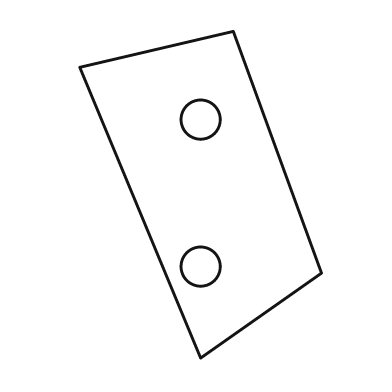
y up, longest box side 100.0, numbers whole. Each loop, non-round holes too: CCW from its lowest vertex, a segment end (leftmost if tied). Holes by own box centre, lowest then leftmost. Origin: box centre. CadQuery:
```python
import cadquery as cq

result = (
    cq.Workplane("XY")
    .moveTo(0.0, -50.0)
    .lineTo(37.0, -24.0)
    .lineTo(10.0, 50.0)
    .lineTo(-37.0, 39.0)
    .close()
    .moveTo(0.0, -22.0)
    .circle(6.0)
    .moveTo(0.0, 23.0)
    .circle(6.0)
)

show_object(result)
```